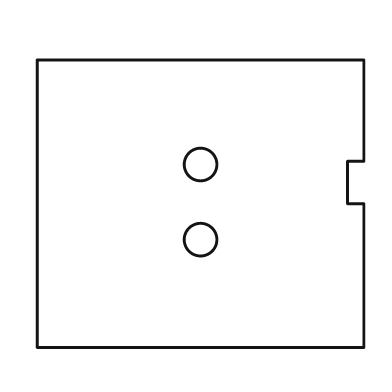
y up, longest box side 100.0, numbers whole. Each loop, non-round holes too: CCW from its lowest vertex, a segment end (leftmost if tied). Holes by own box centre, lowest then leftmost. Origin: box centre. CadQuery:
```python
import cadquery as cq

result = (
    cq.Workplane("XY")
    .moveTo(-50.0, -44.0)
    .lineTo(50.0, -44.0)
    .lineTo(50.0, 0.0)
    .lineTo(45.0, 0.0)
    .lineTo(45.0, 13.0)
    .lineTo(50.0, 13.0)
    .lineTo(50.0, 44.0)
    .lineTo(-50.0, 44.0)
    .close()
    .moveTo(0.0, -11.0)
    .circle(5.0)
    .moveTo(0.0, 12.0)
    .circle(5.0)
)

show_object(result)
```